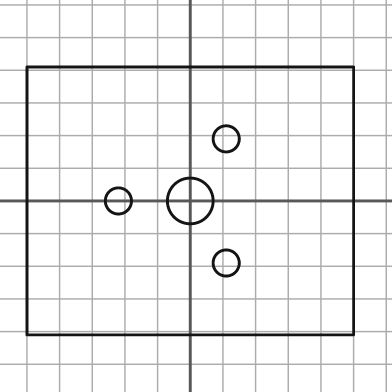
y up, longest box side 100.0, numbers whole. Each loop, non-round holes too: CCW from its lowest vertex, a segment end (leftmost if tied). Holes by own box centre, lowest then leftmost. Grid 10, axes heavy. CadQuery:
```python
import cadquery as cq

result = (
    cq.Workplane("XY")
    .moveTo(-50.0, -41.0)
    .lineTo(50.0, -41.0)
    .lineTo(50.0, 41.0)
    .lineTo(-50.0, 41.0)
    .close()
    .moveTo(11.0, -19.0)
    .circle(4.0)
    .moveTo(-22.0, 0.0)
    .circle(4.0)
    .moveTo(0.0, 0.0)
    .circle(7.0)
    .moveTo(11.0, 19.0)
    .circle(4.0)
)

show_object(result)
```